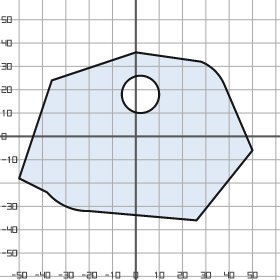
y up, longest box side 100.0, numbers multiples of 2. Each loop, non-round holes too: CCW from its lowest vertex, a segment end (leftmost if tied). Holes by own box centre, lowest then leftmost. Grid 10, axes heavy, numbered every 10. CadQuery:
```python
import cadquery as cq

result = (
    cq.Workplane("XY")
    .moveTo(26.0, -36.0)
    .lineTo(50.0, -6.0)
    .lineTo(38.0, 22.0)
    .threePointArc((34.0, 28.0), (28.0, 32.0))
    .lineTo(0.0, 36.0)
    .lineTo(-36.0, 24.0)
    .lineTo(-50.0, -18.0)
    .lineTo(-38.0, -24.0)
    .threePointArc((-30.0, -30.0), (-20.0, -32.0))
    .close()
    .moveTo(2.0, 18.0)
    .circle(8.0)
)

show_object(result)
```